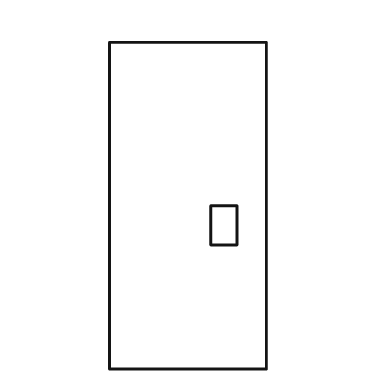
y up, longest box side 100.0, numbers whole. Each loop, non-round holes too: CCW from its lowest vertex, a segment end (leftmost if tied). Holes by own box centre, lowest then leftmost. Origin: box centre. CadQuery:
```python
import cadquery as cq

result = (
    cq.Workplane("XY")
    .moveTo(-24.0, -50.0)
    .lineTo(24.0, -50.0)
    .lineTo(24.0, 50.0)
    .lineTo(-24.0, 50.0)
    .close()
    .moveTo(7.0, -12.0)
    .lineTo(15.0, -12.0)
    .lineTo(15.0, 0.0)
    .lineTo(7.0, 0.0)
    .close()
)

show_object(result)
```